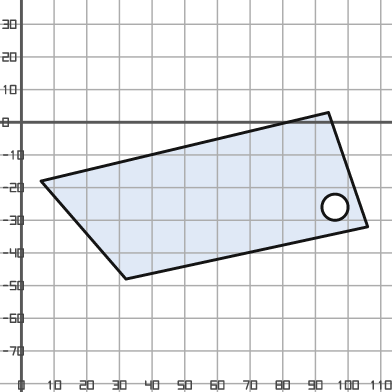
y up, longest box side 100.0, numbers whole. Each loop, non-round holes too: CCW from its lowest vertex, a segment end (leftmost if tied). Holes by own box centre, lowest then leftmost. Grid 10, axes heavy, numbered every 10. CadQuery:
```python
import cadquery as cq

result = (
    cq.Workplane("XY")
    .moveTo(32.0, -48.0)
    .lineTo(106.0, -32.0)
    .lineTo(94.0, 3.0)
    .lineTo(6.0, -18.0)
    .close()
    .moveTo(96.0, -26.0)
    .circle(4.0)
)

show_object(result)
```